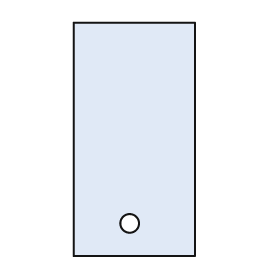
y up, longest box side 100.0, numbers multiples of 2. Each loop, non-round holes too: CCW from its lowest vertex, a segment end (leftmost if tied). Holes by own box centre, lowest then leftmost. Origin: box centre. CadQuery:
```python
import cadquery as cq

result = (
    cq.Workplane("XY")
    .moveTo(-26.0, -50.0)
    .lineTo(26.0, -50.0)
    .lineTo(26.0, 50.0)
    .lineTo(-26.0, 50.0)
    .close()
    .moveTo(-2.0, -36.0)
    .circle(4.0)
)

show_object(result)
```